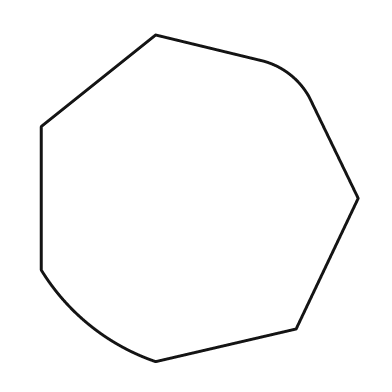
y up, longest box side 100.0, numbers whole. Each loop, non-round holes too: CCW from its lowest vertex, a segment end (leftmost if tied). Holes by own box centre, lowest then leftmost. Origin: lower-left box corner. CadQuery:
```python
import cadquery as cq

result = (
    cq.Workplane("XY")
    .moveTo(35.0, 0.0)
    .lineTo(78.0, 10.0)
    .lineTo(97.0, 50.0)
    .lineTo(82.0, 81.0)
    .threePointArc((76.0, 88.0), (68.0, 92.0))
    .lineTo(35.0, 100.0)
    .lineTo(0.0, 72.0)
    .lineTo(0.0, 28.0)
    .threePointArc((15.0, 11.0), (35.0, 0.0))
    .close()
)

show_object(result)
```